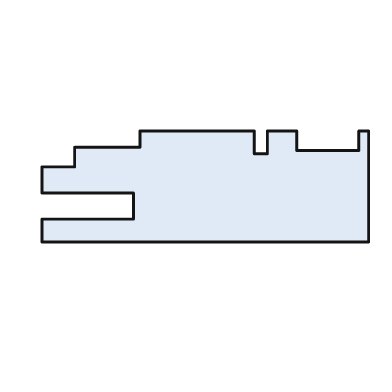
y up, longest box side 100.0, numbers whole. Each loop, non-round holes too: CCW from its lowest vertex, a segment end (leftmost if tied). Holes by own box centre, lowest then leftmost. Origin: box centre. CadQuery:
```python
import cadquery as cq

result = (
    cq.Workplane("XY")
    .moveTo(-50.0, -17.0)
    .lineTo(50.0, -17.0)
    .lineTo(50.0, 17.0)
    .lineTo(47.0, 17.0)
    .lineTo(47.0, 11.0)
    .lineTo(28.0, 11.0)
    .lineTo(28.0, 17.0)
    .lineTo(19.0, 17.0)
    .lineTo(19.0, 10.0)
    .lineTo(15.0, 10.0)
    .lineTo(15.0, 17.0)
    .lineTo(-20.0, 17.0)
    .lineTo(-20.0, 12.0)
    .lineTo(-40.0, 12.0)
    .lineTo(-40.0, 6.0)
    .lineTo(-50.0, 6.0)
    .lineTo(-50.0, -2.0)
    .lineTo(-22.0, -2.0)
    .lineTo(-22.0, -10.0)
    .lineTo(-50.0, -10.0)
    .close()
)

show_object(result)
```